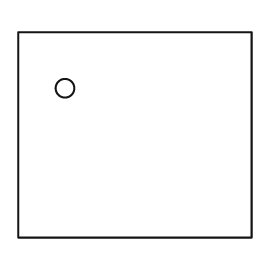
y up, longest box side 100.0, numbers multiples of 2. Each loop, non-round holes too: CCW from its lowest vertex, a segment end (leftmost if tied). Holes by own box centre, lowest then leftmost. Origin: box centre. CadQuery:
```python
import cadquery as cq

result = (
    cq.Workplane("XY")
    .moveTo(-50.0, -44.0)
    .lineTo(50.0, -44.0)
    .lineTo(50.0, 44.0)
    .lineTo(-50.0, 44.0)
    .close()
    .moveTo(-30.0, 20.0)
    .circle(4.0)
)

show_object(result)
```